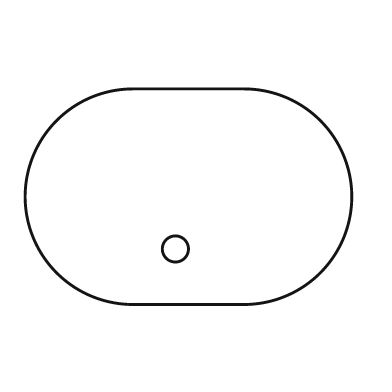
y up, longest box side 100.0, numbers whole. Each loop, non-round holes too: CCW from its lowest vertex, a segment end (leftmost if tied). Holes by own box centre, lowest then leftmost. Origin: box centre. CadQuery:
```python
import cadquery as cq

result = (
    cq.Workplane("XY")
    .moveTo(-17.0, -33.0)
    .lineTo(17.0, -33.0)
    .threePointArc((50.0, 0.0), (17.0, 33.0))
    .lineTo(-17.0, 33.0)
    .threePointArc((-50.0, 0.0), (-17.0, -33.0))
    .close()
    .moveTo(-4.0, -16.0)
    .circle(4.0)
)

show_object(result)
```